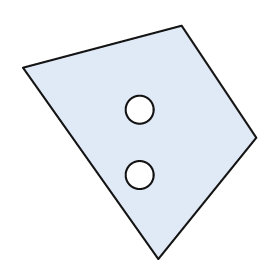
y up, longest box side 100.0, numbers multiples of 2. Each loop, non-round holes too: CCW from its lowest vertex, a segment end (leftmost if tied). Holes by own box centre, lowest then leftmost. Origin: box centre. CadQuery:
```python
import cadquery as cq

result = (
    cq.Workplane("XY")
    .moveTo(8.0, -50.0)
    .lineTo(50.0, 2.0)
    .lineTo(18.0, 50.0)
    .lineTo(-50.0, 32.0)
    .close()
    .moveTo(0.0, -14.0)
    .circle(6.0)
    .moveTo(0.0, 14.0)
    .circle(6.0)
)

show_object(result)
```